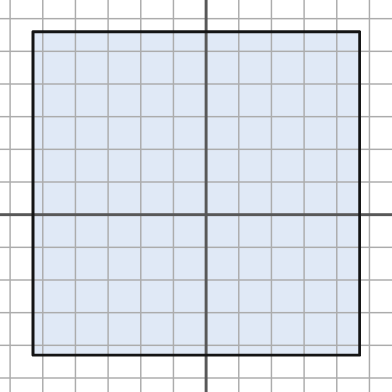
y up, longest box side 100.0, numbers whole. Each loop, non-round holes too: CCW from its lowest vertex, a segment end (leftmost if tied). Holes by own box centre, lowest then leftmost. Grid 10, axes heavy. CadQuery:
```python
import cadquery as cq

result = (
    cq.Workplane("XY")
    .moveTo(-53.0, -43.0)
    .lineTo(47.0, -43.0)
    .lineTo(47.0, 56.0)
    .lineTo(-53.0, 56.0)
    .close()
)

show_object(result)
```